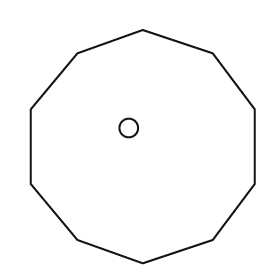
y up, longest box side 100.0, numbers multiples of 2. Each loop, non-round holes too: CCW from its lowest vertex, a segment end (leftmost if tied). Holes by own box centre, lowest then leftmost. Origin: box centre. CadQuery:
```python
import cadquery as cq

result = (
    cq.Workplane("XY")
    .moveTo(0.0, -50.0)
    .lineTo(30.0, -40.0)
    .lineTo(48.0, -16.0)
    .lineTo(48.0, 16.0)
    .lineTo(30.0, 40.0)
    .lineTo(0.0, 50.0)
    .lineTo(-28.0, 40.0)
    .lineTo(-48.0, 16.0)
    .lineTo(-48.0, -16.0)
    .lineTo(-28.0, -40.0)
    .close()
    .moveTo(-6.0, 8.0)
    .circle(4.0)
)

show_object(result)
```